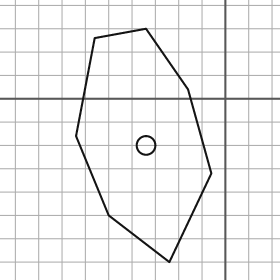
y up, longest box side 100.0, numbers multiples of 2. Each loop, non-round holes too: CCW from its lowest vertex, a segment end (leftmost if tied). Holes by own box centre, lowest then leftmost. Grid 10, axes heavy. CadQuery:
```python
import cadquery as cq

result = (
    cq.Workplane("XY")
    .moveTo(-24.0, -70.0)
    .lineTo(-6.0, -32.0)
    .lineTo(-16.0, 4.0)
    .lineTo(-34.0, 30.0)
    .lineTo(-56.0, 26.0)
    .lineTo(-64.0, -16.0)
    .lineTo(-50.0, -50.0)
    .close()
    .moveTo(-34.0, -20.0)
    .circle(4.0)
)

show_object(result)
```